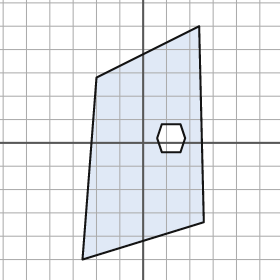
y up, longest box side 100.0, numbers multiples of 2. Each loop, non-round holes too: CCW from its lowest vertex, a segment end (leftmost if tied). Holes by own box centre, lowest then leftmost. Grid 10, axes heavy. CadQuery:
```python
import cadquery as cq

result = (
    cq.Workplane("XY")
    .moveTo(-26.0, -50.0)
    .lineTo(26.0, -34.0)
    .lineTo(24.0, 50.0)
    .lineTo(-20.0, 28.0)
    .close()
    .moveTo(8.0, -4.0)
    .lineTo(16.0, -4.0)
    .lineTo(18.0, 2.0)
    .lineTo(16.0, 8.0)
    .lineTo(8.0, 8.0)
    .lineTo(6.0, 2.0)
    .close()
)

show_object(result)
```